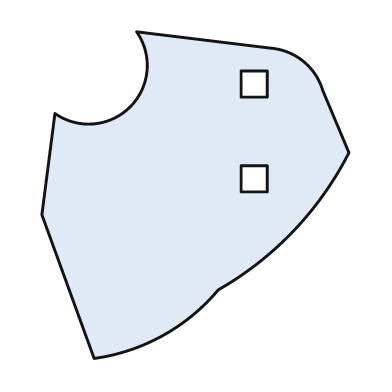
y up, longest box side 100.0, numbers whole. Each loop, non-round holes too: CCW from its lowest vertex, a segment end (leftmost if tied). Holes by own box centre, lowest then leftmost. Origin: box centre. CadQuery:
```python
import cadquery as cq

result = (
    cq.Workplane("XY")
    .moveTo(-31.0, -50.0)
    .threePointArc((-10.0, -43.0), (7.0, -29.0))
    .threePointArc((30.0, -11.0), (47.0, 13.0))
    .lineTo(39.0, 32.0)
    .threePointArc((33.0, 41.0), (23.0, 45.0))
    .lineTo(-18.0, 50.0)
    .threePointArc((-20.0, 27.0), (-43.0, 25.0))
    .lineTo(-47.0, -6.0)
    .close()
    .moveTo(14.0, 1.0)
    .lineTo(22.0, 1.0)
    .lineTo(22.0, 9.0)
    .lineTo(14.0, 9.0)
    .close()
    .moveTo(14.0, 30.0)
    .lineTo(22.0, 30.0)
    .lineTo(22.0, 38.0)
    .lineTo(14.0, 38.0)
    .close()
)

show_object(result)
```